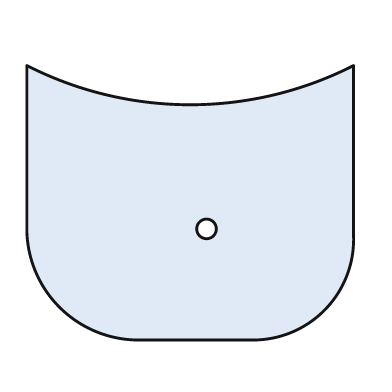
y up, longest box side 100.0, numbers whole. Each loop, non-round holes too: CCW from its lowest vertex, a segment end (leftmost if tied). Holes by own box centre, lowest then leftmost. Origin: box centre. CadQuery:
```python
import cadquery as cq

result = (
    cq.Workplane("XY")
    .moveTo(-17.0, -42.0)
    .lineTo(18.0, -42.0)
    .threePointArc((41.0, -33.0), (50.0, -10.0))
    .lineTo(50.0, 42.0)
    .threePointArc((0.0, 30.0), (-50.0, 42.0))
    .lineTo(-50.0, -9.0)
    .threePointArc((-40.0, -32.0), (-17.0, -42.0))
    .close()
    .moveTo(5.0, -8.0)
    .circle(3.0)
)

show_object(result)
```